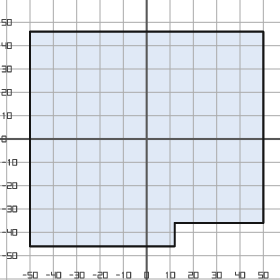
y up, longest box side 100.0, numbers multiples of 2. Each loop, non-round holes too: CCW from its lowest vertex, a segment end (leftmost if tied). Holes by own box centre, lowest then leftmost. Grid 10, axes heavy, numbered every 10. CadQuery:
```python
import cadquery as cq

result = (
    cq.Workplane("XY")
    .moveTo(-50.0, -46.0)
    .lineTo(12.0, -46.0)
    .lineTo(12.0, -36.0)
    .lineTo(50.0, -36.0)
    .lineTo(50.0, 46.0)
    .lineTo(-50.0, 46.0)
    .close()
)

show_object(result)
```